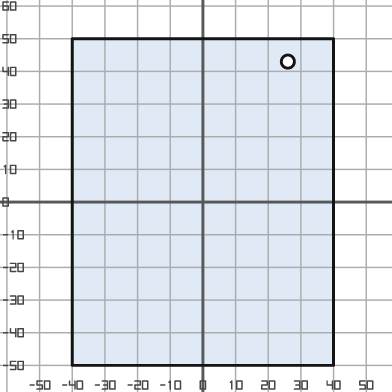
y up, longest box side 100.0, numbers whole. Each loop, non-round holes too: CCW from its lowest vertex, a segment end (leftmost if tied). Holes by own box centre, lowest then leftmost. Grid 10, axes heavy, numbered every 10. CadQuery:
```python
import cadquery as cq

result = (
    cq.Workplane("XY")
    .moveTo(-40.0, -50.0)
    .lineTo(40.0, -50.0)
    .lineTo(40.0, 50.0)
    .lineTo(-40.0, 50.0)
    .close()
    .moveTo(26.0, 43.0)
    .circle(2.0)
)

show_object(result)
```